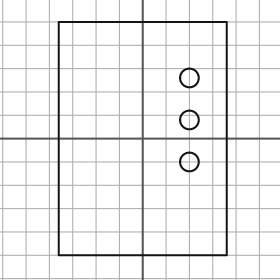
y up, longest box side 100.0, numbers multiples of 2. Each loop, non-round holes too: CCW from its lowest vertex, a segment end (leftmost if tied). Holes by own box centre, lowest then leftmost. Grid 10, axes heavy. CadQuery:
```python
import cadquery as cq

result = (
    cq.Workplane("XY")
    .moveTo(-36.0, -50.0)
    .lineTo(36.0, -50.0)
    .lineTo(36.0, 50.0)
    .lineTo(-36.0, 50.0)
    .close()
    .moveTo(20.0, -10.0)
    .circle(4.0)
    .moveTo(20.0, 8.0)
    .circle(4.0)
    .moveTo(20.0, 26.0)
    .circle(4.0)
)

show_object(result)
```